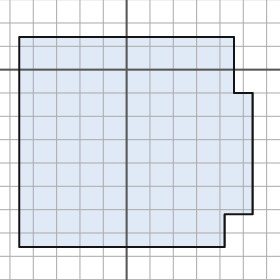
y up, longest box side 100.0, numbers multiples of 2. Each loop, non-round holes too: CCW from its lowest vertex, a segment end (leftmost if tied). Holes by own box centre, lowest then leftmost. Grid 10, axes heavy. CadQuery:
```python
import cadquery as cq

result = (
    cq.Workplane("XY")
    .moveTo(-46.0, -76.0)
    .lineTo(42.0, -76.0)
    .lineTo(42.0, -62.0)
    .lineTo(54.0, -62.0)
    .lineTo(54.0, -10.0)
    .lineTo(46.0, -10.0)
    .lineTo(46.0, 14.0)
    .lineTo(-46.0, 14.0)
    .close()
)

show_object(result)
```